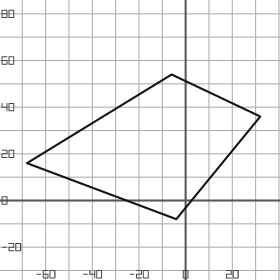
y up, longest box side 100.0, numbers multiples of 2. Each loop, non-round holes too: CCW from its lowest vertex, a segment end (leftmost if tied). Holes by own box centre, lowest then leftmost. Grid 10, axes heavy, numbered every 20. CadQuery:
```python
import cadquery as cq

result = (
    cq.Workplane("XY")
    .moveTo(-4.0, -8.0)
    .lineTo(32.0, 36.0)
    .lineTo(-6.0, 54.0)
    .lineTo(-68.0, 16.0)
    .close()
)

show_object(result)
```